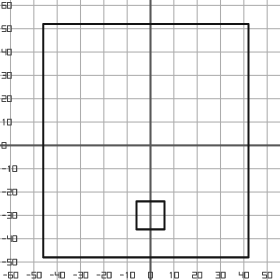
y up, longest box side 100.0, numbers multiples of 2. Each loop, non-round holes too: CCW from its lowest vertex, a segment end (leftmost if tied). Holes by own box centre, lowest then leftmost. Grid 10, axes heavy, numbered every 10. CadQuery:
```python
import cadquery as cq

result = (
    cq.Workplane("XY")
    .moveTo(-46.0, -48.0)
    .lineTo(42.0, -48.0)
    .lineTo(42.0, 52.0)
    .lineTo(-46.0, 52.0)
    .close()
    .moveTo(-6.0, -36.0)
    .lineTo(6.0, -36.0)
    .lineTo(6.0, -24.0)
    .lineTo(-6.0, -24.0)
    .close()
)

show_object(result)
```